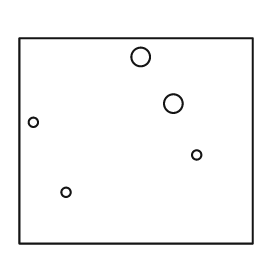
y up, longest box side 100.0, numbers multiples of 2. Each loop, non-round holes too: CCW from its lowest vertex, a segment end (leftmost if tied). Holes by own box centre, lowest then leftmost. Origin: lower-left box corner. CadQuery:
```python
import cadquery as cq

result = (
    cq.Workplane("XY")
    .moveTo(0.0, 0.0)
    .lineTo(100.0, 0.0)
    .lineTo(100.0, 88.0)
    .lineTo(0.0, 88.0)
    .close()
    .moveTo(20.0, 22.0)
    .circle(2.0)
    .moveTo(76.0, 38.0)
    .circle(2.0)
    .moveTo(6.0, 52.0)
    .circle(2.0)
    .moveTo(66.0, 60.0)
    .circle(4.0)
    .moveTo(52.0, 80.0)
    .circle(4.0)
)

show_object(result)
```